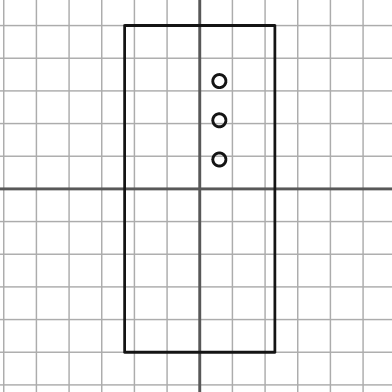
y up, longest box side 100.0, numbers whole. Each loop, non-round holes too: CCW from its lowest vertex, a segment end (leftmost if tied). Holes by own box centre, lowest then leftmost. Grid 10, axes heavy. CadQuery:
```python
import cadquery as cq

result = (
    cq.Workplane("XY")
    .moveTo(-23.0, -50.0)
    .lineTo(23.0, -50.0)
    .lineTo(23.0, 50.0)
    .lineTo(-23.0, 50.0)
    .close()
    .moveTo(6.0, 9.0)
    .circle(2.0)
    .moveTo(6.0, 21.0)
    .circle(2.0)
    .moveTo(6.0, 33.0)
    .circle(2.0)
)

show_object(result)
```